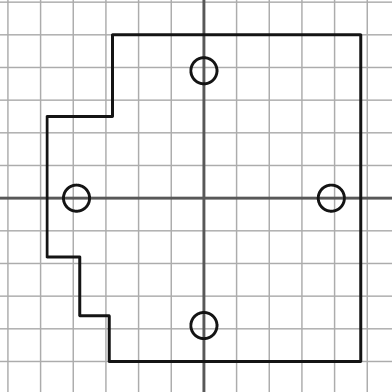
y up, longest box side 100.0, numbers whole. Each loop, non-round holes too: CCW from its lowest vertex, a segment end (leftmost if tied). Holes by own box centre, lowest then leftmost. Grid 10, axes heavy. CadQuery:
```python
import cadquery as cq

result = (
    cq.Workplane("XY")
    .moveTo(-29.0, -50.0)
    .lineTo(48.0, -50.0)
    .lineTo(48.0, 50.0)
    .lineTo(-28.0, 50.0)
    .lineTo(-28.0, 25.0)
    .lineTo(-48.0, 25.0)
    .lineTo(-48.0, -18.0)
    .lineTo(-38.0, -18.0)
    .lineTo(-38.0, -36.0)
    .lineTo(-29.0, -36.0)
    .close()
    .moveTo(0.0, -39.0)
    .circle(4.0)
    .moveTo(-39.0, 0.0)
    .circle(4.0)
    .moveTo(39.0, 0.0)
    .circle(4.0)
    .moveTo(0.0, 39.0)
    .circle(4.0)
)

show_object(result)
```